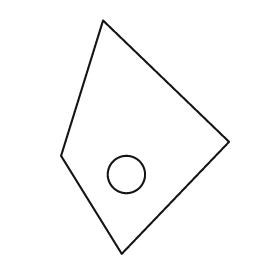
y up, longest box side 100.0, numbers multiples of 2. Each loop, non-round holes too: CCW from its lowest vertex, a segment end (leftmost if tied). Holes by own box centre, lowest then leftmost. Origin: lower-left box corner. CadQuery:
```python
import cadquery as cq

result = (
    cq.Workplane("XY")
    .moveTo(26.0, 0.0)
    .lineTo(72.0, 48.0)
    .lineTo(18.0, 100.0)
    .lineTo(0.0, 42.0)
    .close()
    .moveTo(28.0, 34.0)
    .circle(8.0)
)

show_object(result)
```